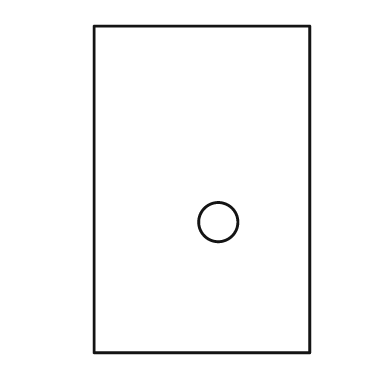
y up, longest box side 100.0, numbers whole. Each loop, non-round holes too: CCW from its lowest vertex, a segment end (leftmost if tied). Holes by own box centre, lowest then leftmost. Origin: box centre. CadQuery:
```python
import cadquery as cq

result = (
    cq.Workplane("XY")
    .moveTo(-33.0, -50.0)
    .lineTo(33.0, -50.0)
    .lineTo(33.0, 50.0)
    .lineTo(-33.0, 50.0)
    .close()
    .moveTo(5.0, -10.0)
    .circle(6.0)
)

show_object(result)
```